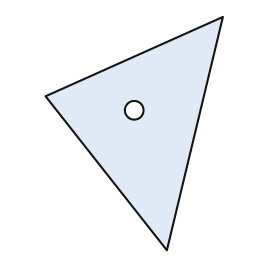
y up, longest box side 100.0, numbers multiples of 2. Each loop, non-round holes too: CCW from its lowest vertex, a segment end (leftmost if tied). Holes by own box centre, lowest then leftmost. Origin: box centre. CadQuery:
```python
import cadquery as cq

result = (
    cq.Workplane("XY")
    .moveTo(14.0, -50.0)
    .lineTo(38.0, 50.0)
    .lineTo(-38.0, 16.0)
    .close()
    .moveTo(0.0, 10.0)
    .circle(4.0)
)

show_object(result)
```